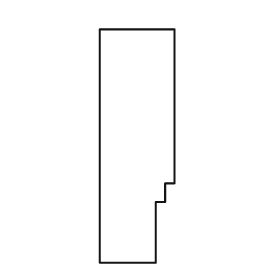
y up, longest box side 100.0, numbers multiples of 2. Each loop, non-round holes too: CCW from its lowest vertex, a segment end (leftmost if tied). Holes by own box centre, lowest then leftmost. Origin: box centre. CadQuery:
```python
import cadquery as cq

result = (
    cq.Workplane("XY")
    .moveTo(-16.0, -50.0)
    .lineTo(8.0, -50.0)
    .lineTo(8.0, -24.0)
    .lineTo(12.0, -24.0)
    .lineTo(12.0, -16.0)
    .lineTo(16.0, -16.0)
    .lineTo(16.0, 50.0)
    .lineTo(-16.0, 50.0)
    .close()
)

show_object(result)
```